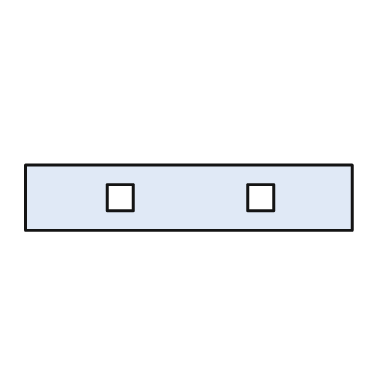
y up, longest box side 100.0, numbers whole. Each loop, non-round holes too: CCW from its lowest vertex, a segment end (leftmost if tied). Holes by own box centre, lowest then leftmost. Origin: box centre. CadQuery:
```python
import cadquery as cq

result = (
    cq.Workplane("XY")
    .moveTo(-50.0, -10.0)
    .lineTo(50.0, -10.0)
    .lineTo(50.0, 10.0)
    .lineTo(-50.0, 10.0)
    .close()
    .moveTo(-25.0, -4.0)
    .lineTo(-17.0, -4.0)
    .lineTo(-17.0, 4.0)
    .lineTo(-25.0, 4.0)
    .close()
    .moveTo(18.0, -4.0)
    .lineTo(26.0, -4.0)
    .lineTo(26.0, 4.0)
    .lineTo(18.0, 4.0)
    .close()
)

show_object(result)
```